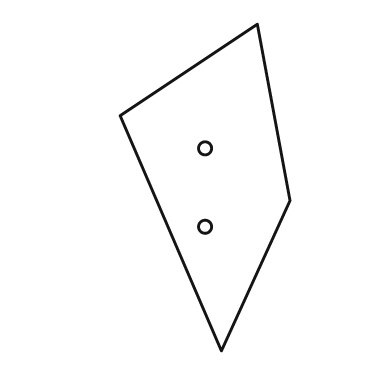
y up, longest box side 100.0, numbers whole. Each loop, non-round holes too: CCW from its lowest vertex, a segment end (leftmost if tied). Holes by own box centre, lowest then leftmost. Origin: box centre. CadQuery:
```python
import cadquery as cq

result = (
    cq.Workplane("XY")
    .moveTo(5.0, -50.0)
    .lineTo(26.0, -4.0)
    .lineTo(16.0, 50.0)
    .lineTo(-26.0, 22.0)
    .close()
    .moveTo(0.0, -12.0)
    .circle(2.0)
    .moveTo(0.0, 12.0)
    .circle(2.0)
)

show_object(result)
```